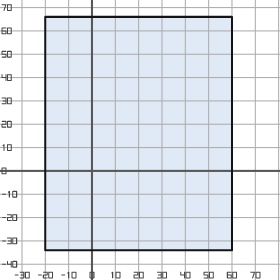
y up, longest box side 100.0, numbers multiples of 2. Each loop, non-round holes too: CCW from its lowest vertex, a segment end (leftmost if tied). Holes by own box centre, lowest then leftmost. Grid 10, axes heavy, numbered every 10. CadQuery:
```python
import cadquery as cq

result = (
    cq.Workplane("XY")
    .moveTo(-20.0, -34.0)
    .lineTo(60.0, -34.0)
    .lineTo(60.0, 66.0)
    .lineTo(-20.0, 66.0)
    .close()
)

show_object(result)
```